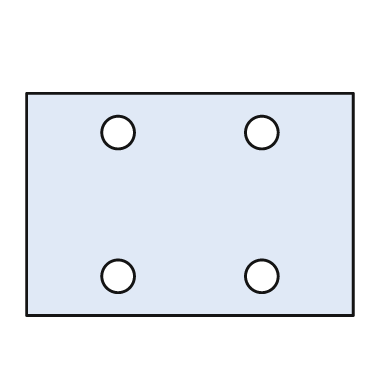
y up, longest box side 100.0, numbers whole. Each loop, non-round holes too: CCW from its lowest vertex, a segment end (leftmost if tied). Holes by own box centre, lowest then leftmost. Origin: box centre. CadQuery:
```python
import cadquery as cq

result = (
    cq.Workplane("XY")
    .moveTo(-50.0, -34.0)
    .lineTo(50.0, -34.0)
    .lineTo(50.0, 34.0)
    .lineTo(-50.0, 34.0)
    .close()
    .moveTo(-22.0, -22.0)
    .circle(5.0)
    .moveTo(22.0, -22.0)
    .circle(5.0)
    .moveTo(-22.0, 22.0)
    .circle(5.0)
    .moveTo(22.0, 22.0)
    .circle(5.0)
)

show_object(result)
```